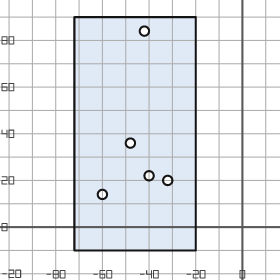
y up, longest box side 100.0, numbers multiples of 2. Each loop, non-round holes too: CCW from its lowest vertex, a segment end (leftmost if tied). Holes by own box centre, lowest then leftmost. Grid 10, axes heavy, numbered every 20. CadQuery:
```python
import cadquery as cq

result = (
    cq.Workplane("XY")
    .moveTo(-72.0, -10.0)
    .lineTo(-20.0, -10.0)
    .lineTo(-20.0, 90.0)
    .lineTo(-72.0, 90.0)
    .close()
    .moveTo(-60.0, 14.0)
    .circle(2.0)
    .moveTo(-32.0, 20.0)
    .circle(2.0)
    .moveTo(-40.0, 22.0)
    .circle(2.0)
    .moveTo(-48.0, 36.0)
    .circle(2.0)
    .moveTo(-42.0, 84.0)
    .circle(2.0)
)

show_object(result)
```